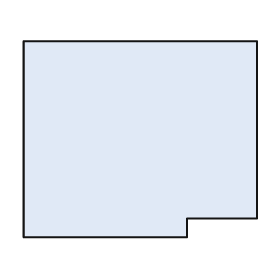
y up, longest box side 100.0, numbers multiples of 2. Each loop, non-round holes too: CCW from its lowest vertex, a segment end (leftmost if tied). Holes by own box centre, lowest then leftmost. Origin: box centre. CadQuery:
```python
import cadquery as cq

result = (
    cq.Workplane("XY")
    .moveTo(-50.0, -42.0)
    .lineTo(20.0, -42.0)
    .lineTo(20.0, -34.0)
    .lineTo(50.0, -34.0)
    .lineTo(50.0, 42.0)
    .lineTo(-50.0, 42.0)
    .close()
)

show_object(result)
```